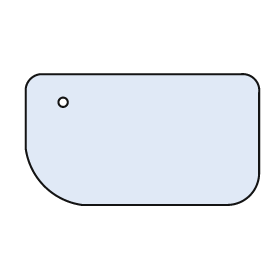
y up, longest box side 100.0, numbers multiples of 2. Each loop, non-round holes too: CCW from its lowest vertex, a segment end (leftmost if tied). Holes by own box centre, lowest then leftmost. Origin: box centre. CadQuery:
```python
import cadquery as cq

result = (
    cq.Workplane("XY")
    .moveTo(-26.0, -28.0)
    .lineTo(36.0, -28.0)
    .threePointArc((46.0, -24.0), (50.0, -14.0))
    .lineTo(50.0, 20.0)
    .threePointArc((48.0, 26.0), (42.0, 28.0))
    .lineTo(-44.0, 28.0)
    .threePointArc((-48.0, 26.0), (-50.0, 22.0))
    .lineTo(-50.0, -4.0)
    .threePointArc((-42.0, -20.0), (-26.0, -28.0))
    .close()
    .moveTo(-34.0, 16.0)
    .circle(2.0)
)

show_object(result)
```